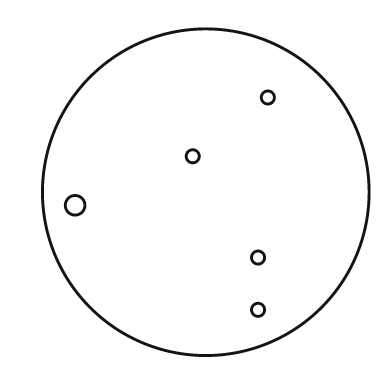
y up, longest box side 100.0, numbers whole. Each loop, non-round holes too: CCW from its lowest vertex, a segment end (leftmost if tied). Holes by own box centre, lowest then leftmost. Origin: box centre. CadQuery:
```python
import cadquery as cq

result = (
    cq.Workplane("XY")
    .moveTo(0.0, 0.0)
    .circle(50.0)
    .moveTo(16.0, -36.0)
    .circle(2.0)
    .moveTo(16.0, -20.0)
    .circle(2.0)
    .moveTo(-40.0, -4.0)
    .circle(3.0)
    .moveTo(-4.0, 11.0)
    .circle(2.0)
    .moveTo(19.0, 29.0)
    .circle(2.0)
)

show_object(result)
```